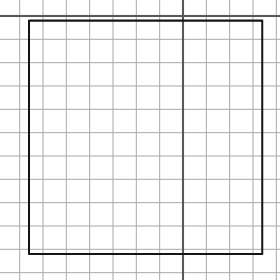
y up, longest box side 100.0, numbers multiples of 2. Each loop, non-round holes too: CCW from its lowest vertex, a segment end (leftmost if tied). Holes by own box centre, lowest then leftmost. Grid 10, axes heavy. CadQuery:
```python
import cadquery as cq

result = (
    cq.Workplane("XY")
    .moveTo(-66.0, -102.0)
    .lineTo(34.0, -102.0)
    .lineTo(34.0, -2.0)
    .lineTo(-66.0, -2.0)
    .close()
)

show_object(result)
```